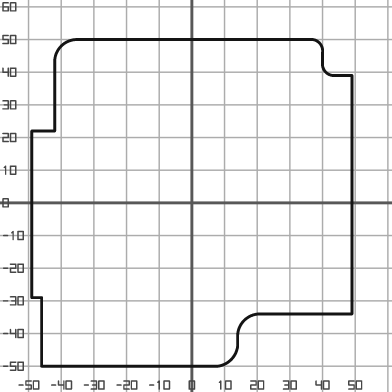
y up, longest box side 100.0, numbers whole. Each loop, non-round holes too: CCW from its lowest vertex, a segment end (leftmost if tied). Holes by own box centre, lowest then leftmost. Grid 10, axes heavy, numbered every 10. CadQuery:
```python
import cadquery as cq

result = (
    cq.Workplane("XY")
    .moveTo(-46.0, -50.0)
    .lineTo(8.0, -50.0)
    .threePointArc((12.0, -48.0), (14.0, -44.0))
    .lineTo(14.0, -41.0)
    .threePointArc((16.0, -36.0), (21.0, -34.0))
    .lineTo(49.0, -34.0)
    .lineTo(49.0, 39.0)
    .lineTo(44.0, 39.0)
    .threePointArc((41.0, 40.0), (40.0, 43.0))
    .lineTo(40.0, 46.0)
    .threePointArc((39.0, 49.0), (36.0, 50.0))
    .lineTo(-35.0, 50.0)
    .threePointArc((-40.0, 48.0), (-42.0, 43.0))
    .lineTo(-42.0, 22.0)
    .lineTo(-49.0, 22.0)
    .lineTo(-49.0, -29.0)
    .lineTo(-46.0, -29.0)
    .close()
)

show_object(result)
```